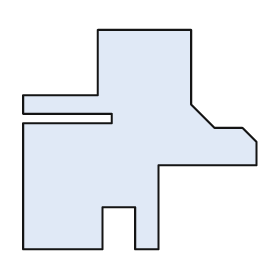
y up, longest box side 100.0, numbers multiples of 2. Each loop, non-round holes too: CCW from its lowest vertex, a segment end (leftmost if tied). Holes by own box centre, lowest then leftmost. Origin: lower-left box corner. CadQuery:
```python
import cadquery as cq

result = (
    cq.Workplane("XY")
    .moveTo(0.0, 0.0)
    .lineTo(34.0, 0.0)
    .lineTo(34.0, 18.0)
    .lineTo(48.0, 18.0)
    .lineTo(48.0, 0.0)
    .lineTo(58.0, 0.0)
    .lineTo(58.0, 36.0)
    .lineTo(100.0, 36.0)
    .lineTo(100.0, 46.0)
    .lineTo(94.0, 52.0)
    .lineTo(82.0, 52.0)
    .lineTo(72.0, 62.0)
    .lineTo(72.0, 94.0)
    .lineTo(32.0, 94.0)
    .lineTo(32.0, 66.0)
    .lineTo(0.0, 66.0)
    .lineTo(0.0, 58.0)
    .lineTo(38.0, 58.0)
    .lineTo(38.0, 54.0)
    .lineTo(0.0, 54.0)
    .close()
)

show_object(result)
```